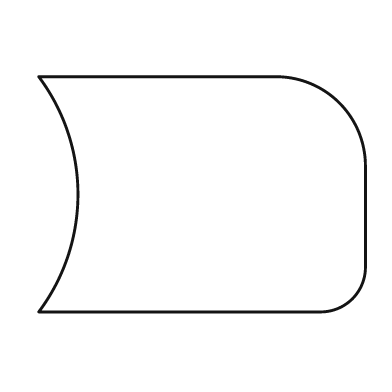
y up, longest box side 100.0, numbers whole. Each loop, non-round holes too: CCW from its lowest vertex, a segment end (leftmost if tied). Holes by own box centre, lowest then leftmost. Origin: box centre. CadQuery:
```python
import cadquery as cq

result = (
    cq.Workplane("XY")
    .moveTo(-50.0, -36.0)
    .lineTo(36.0, -36.0)
    .threePointArc((46.0, -32.0), (50.0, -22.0))
    .lineTo(50.0, 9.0)
    .threePointArc((42.0, 28.0), (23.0, 36.0))
    .lineTo(-50.0, 36.0)
    .threePointArc((-38.0, 0.0), (-50.0, -36.0))
    .close()
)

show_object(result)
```